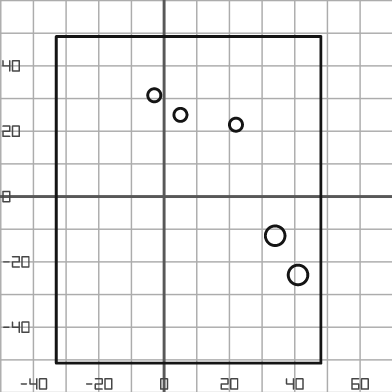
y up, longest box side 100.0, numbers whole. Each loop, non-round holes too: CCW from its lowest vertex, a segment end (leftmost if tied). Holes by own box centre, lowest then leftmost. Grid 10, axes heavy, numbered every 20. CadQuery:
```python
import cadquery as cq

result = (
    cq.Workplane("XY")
    .moveTo(-33.0, -51.0)
    .lineTo(48.0, -51.0)
    .lineTo(48.0, 49.0)
    .lineTo(-33.0, 49.0)
    .close()
    .moveTo(41.0, -24.0)
    .circle(3.0)
    .moveTo(34.0, -12.0)
    .circle(3.0)
    .moveTo(22.0, 22.0)
    .circle(2.0)
    .moveTo(5.0, 25.0)
    .circle(2.0)
    .moveTo(-3.0, 31.0)
    .circle(2.0)
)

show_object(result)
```